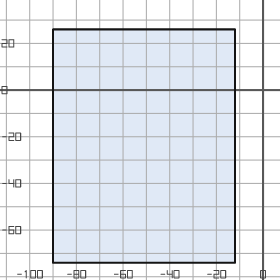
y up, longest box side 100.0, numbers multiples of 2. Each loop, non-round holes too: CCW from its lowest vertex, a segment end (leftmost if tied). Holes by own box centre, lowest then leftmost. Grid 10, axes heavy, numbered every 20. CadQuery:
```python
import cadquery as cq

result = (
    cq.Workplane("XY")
    .moveTo(-90.0, -74.0)
    .lineTo(-12.0, -74.0)
    .lineTo(-12.0, 26.0)
    .lineTo(-90.0, 26.0)
    .close()
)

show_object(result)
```